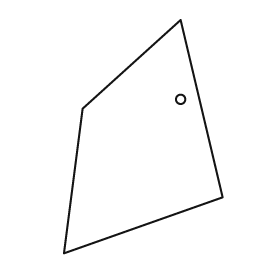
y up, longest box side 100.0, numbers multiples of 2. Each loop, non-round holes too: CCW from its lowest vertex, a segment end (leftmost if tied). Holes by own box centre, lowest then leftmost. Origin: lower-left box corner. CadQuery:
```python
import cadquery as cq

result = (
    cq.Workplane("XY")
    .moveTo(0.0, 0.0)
    .lineTo(68.0, 24.0)
    .lineTo(50.0, 100.0)
    .lineTo(8.0, 62.0)
    .close()
    .moveTo(50.0, 66.0)
    .circle(2.0)
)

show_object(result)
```